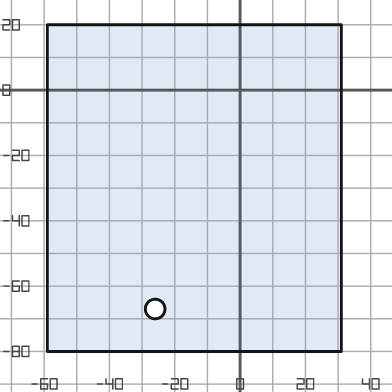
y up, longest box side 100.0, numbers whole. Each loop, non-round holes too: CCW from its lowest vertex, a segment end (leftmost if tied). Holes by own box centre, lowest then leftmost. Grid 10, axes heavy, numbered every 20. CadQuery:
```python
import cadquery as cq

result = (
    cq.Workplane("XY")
    .moveTo(-59.0, -80.0)
    .lineTo(31.0, -80.0)
    .lineTo(31.0, 20.0)
    .lineTo(-59.0, 20.0)
    .close()
    .moveTo(-26.0, -67.0)
    .circle(3.0)
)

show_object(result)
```